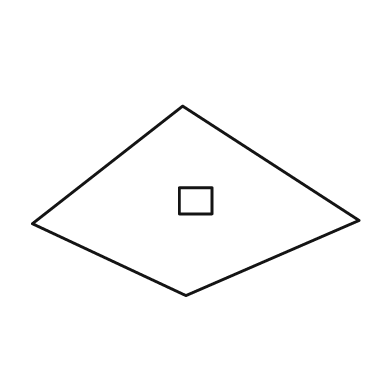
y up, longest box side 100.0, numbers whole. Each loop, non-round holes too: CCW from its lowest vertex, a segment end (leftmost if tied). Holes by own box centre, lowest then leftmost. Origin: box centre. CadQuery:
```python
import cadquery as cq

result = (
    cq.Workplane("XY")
    .moveTo(-3.0, -29.0)
    .lineTo(50.0, -6.0)
    .lineTo(-4.0, 29.0)
    .lineTo(-50.0, -7.0)
    .close()
    .moveTo(-5.0, -4.0)
    .lineTo(5.0, -4.0)
    .lineTo(5.0, 4.0)
    .lineTo(-5.0, 4.0)
    .close()
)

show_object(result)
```